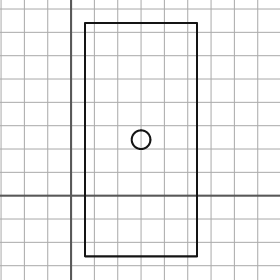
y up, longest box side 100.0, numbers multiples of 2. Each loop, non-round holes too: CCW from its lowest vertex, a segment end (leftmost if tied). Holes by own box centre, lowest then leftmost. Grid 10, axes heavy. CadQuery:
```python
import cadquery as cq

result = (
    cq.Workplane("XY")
    .moveTo(6.0, -26.0)
    .lineTo(54.0, -26.0)
    .lineTo(54.0, 74.0)
    .lineTo(6.0, 74.0)
    .close()
    .moveTo(30.0, 24.0)
    .circle(4.0)
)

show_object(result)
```